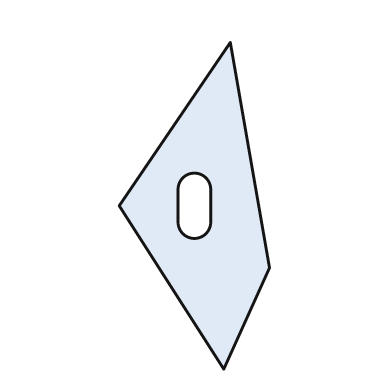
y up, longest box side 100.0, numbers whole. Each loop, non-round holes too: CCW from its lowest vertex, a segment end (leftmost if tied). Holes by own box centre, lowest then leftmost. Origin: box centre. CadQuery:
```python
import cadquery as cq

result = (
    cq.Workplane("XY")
    .moveTo(9.0, -50.0)
    .lineTo(23.0, -19.0)
    .lineTo(11.0, 50.0)
    .lineTo(-23.0, 0.0)
    .close()
    .moveTo(-5.0, -5.0)
    .threePointArc((0.0, -10.0), (5.0, -5.0))
    .lineTo(5.0, 5.0)
    .threePointArc((0.0, 10.0), (-5.0, 5.0))
    .close()
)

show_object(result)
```